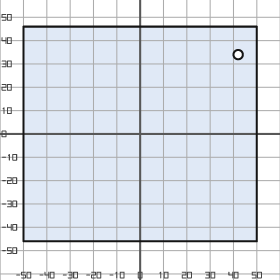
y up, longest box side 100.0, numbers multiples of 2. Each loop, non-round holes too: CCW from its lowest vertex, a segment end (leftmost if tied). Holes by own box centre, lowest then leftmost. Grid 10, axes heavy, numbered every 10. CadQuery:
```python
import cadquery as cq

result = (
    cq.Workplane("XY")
    .moveTo(-50.0, -46.0)
    .lineTo(50.0, -46.0)
    .lineTo(50.0, 46.0)
    .lineTo(-50.0, 46.0)
    .close()
    .moveTo(42.0, 34.0)
    .circle(2.0)
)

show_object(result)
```